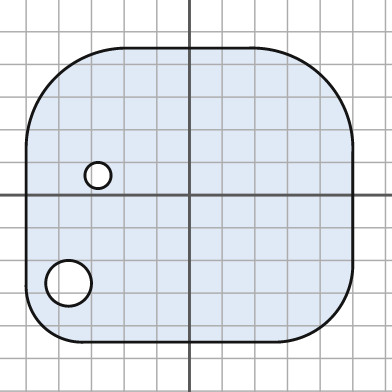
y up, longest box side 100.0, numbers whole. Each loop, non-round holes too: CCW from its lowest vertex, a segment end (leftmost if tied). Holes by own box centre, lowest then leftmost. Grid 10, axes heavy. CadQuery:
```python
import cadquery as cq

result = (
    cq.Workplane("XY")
    .moveTo(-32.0, -45.0)
    .lineTo(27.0, -45.0)
    .threePointArc((43.0, -38.0), (50.0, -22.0))
    .lineTo(50.0, 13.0)
    .threePointArc((41.0, 36.0), (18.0, 45.0))
    .lineTo(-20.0, 45.0)
    .threePointArc((-41.0, 36.0), (-50.0, 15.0))
    .lineTo(-50.0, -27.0)
    .threePointArc((-45.0, -40.0), (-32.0, -45.0))
    .close()
    .moveTo(-37.0, -27.0)
    .circle(7.0)
    .moveTo(-28.0, 6.0)
    .circle(4.0)
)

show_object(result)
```